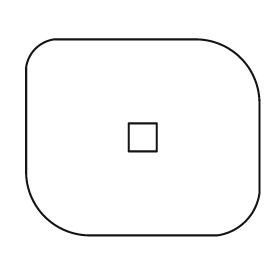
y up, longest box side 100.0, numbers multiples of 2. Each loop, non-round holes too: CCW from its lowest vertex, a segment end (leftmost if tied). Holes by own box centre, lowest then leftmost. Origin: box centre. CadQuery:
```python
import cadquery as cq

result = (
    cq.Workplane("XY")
    .moveTo(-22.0, -42.0)
    .lineTo(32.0, -42.0)
    .threePointArc((44.0, -36.0), (50.0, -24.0))
    .lineTo(50.0, 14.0)
    .threePointArc((42.0, 34.0), (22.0, 42.0))
    .lineTo(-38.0, 42.0)
    .threePointArc((-46.0, 38.0), (-50.0, 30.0))
    .lineTo(-50.0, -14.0)
    .threePointArc((-42.0, -34.0), (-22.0, -42.0))
    .close()
    .moveTo(-6.0, -6.0)
    .lineTo(6.0, -6.0)
    .lineTo(6.0, 6.0)
    .lineTo(-6.0, 6.0)
    .close()
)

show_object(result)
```